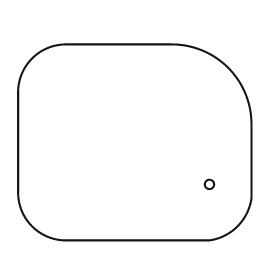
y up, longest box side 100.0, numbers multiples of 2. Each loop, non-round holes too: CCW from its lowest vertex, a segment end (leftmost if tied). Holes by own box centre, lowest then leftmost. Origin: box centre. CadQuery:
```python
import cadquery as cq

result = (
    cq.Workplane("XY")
    .moveTo(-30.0, -42.0)
    .lineTo(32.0, -42.0)
    .threePointArc((44.0, -36.0), (50.0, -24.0))
    .lineTo(50.0, 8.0)
    .threePointArc((40.0, 32.0), (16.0, 42.0))
    .lineTo(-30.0, 42.0)
    .threePointArc((-44.0, 36.0), (-50.0, 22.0))
    .lineTo(-50.0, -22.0)
    .threePointArc((-44.0, -36.0), (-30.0, -42.0))
    .close()
    .moveTo(32.0, -18.0)
    .circle(2.0)
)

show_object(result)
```